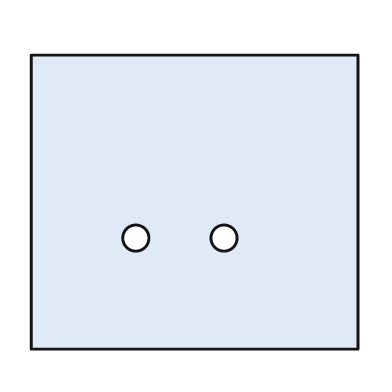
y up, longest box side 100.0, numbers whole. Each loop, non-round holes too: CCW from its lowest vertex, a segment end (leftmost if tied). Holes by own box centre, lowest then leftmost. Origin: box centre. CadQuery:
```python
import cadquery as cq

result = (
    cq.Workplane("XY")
    .moveTo(-50.0, -45.0)
    .lineTo(50.0, -45.0)
    .lineTo(50.0, 45.0)
    .lineTo(-50.0, 45.0)
    .close()
    .moveTo(-18.0, -11.0)
    .circle(4.0)
    .moveTo(9.0, -11.0)
    .circle(4.0)
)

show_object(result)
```